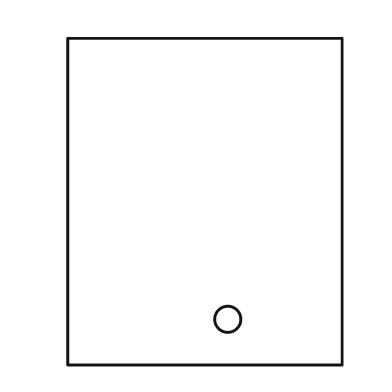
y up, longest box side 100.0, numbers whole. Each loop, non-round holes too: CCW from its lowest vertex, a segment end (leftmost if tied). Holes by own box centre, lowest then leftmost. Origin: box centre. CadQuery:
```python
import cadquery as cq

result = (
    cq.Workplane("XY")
    .moveTo(-42.0, -50.0)
    .lineTo(42.0, -50.0)
    .lineTo(42.0, 50.0)
    .lineTo(-42.0, 50.0)
    .close()
    .moveTo(7.0, -36.0)
    .circle(4.0)
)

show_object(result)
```